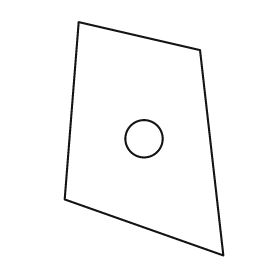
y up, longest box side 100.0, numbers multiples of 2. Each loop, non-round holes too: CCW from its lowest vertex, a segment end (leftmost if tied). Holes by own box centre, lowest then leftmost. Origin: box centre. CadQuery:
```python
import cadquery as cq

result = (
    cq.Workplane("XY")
    .moveTo(34.0, -50.0)
    .lineTo(24.0, 38.0)
    .lineTo(-28.0, 50.0)
    .lineTo(-34.0, -26.0)
    .close()
    .moveTo(0.0, 0.0)
    .circle(8.0)
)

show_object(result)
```